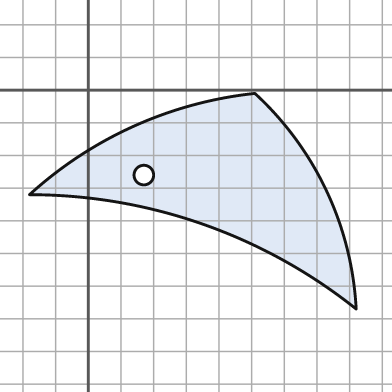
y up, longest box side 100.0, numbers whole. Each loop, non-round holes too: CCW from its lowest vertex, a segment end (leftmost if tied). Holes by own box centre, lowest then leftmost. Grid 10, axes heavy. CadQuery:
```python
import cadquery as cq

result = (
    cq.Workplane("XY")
    .moveTo(82.0, -67.0)
    .threePointArc((73.0, -31.0), (51.0, -1.0))
    .threePointArc((14.0, -11.0), (-18.0, -32.0))
    .threePointArc((35.0, -41.0), (82.0, -67.0))
    .close()
    .moveTo(17.0, -26.0)
    .circle(3.0)
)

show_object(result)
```